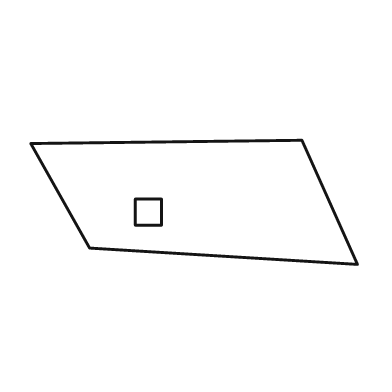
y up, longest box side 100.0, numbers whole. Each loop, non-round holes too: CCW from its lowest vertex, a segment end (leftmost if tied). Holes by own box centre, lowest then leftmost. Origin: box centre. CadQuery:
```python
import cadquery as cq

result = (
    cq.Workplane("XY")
    .moveTo(50.0, -19.0)
    .lineTo(33.0, 19.0)
    .lineTo(-50.0, 18.0)
    .lineTo(-32.0, -14.0)
    .close()
    .moveTo(-18.0, -7.0)
    .lineTo(-10.0, -7.0)
    .lineTo(-10.0, 1.0)
    .lineTo(-18.0, 1.0)
    .close()
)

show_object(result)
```